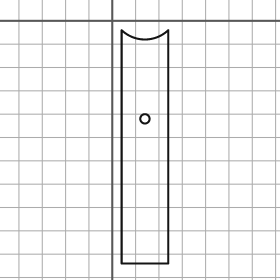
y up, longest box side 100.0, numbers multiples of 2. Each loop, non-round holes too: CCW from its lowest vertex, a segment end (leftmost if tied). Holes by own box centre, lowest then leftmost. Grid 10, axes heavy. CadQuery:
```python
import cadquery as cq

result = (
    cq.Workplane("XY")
    .moveTo(4.0, -104.0)
    .lineTo(24.0, -104.0)
    .lineTo(24.0, -4.0)
    .threePointArc((14.0, -8.0), (4.0, -4.0))
    .close()
    .moveTo(14.0, -42.0)
    .circle(2.0)
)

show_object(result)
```